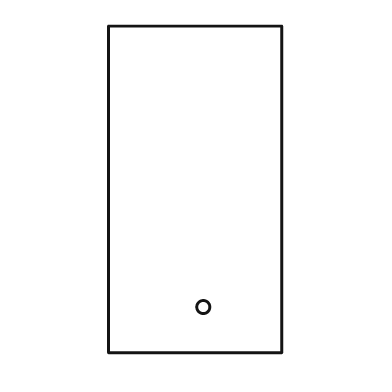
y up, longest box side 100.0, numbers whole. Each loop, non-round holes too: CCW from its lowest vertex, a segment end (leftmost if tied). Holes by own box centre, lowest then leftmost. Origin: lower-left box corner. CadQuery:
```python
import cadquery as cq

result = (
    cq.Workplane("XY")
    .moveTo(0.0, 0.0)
    .lineTo(53.0, 0.0)
    .lineTo(53.0, 100.0)
    .lineTo(0.0, 100.0)
    .close()
    .moveTo(29.0, 14.0)
    .circle(2.0)
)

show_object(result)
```